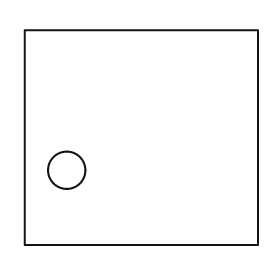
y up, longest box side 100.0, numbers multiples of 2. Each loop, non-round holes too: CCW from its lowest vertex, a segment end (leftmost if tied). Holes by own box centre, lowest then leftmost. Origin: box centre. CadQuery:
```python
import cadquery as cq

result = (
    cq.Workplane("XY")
    .moveTo(-50.0, -46.0)
    .lineTo(50.0, -46.0)
    .lineTo(50.0, 46.0)
    .lineTo(-50.0, 46.0)
    .close()
    .moveTo(-32.0, -14.0)
    .circle(8.0)
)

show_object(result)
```